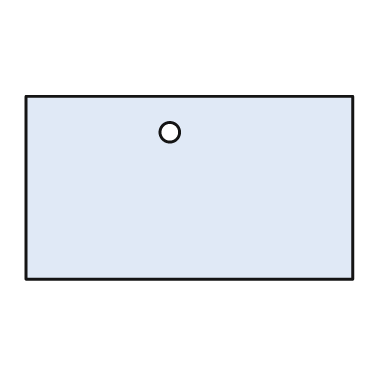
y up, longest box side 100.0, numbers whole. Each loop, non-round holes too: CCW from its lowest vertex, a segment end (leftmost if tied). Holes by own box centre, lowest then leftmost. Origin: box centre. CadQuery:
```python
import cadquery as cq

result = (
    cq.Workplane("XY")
    .moveTo(-50.0, -28.0)
    .lineTo(50.0, -28.0)
    .lineTo(50.0, 28.0)
    .lineTo(-50.0, 28.0)
    .close()
    .moveTo(-6.0, 17.0)
    .circle(3.0)
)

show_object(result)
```